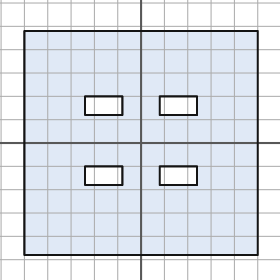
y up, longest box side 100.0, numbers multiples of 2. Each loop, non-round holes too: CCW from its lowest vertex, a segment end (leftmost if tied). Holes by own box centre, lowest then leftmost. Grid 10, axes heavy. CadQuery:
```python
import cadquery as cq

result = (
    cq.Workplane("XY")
    .moveTo(-50.0, -48.0)
    .lineTo(50.0, -48.0)
    .lineTo(50.0, 48.0)
    .lineTo(-50.0, 48.0)
    .close()
    .moveTo(-24.0, -18.0)
    .lineTo(-8.0, -18.0)
    .lineTo(-8.0, -10.0)
    .lineTo(-24.0, -10.0)
    .close()
    .moveTo(8.0, -18.0)
    .lineTo(24.0, -18.0)
    .lineTo(24.0, -10.0)
    .lineTo(8.0, -10.0)
    .close()
    .moveTo(-24.0, 12.0)
    .lineTo(-8.0, 12.0)
    .lineTo(-8.0, 20.0)
    .lineTo(-24.0, 20.0)
    .close()
    .moveTo(8.0, 12.0)
    .lineTo(24.0, 12.0)
    .lineTo(24.0, 20.0)
    .lineTo(8.0, 20.0)
    .close()
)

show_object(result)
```